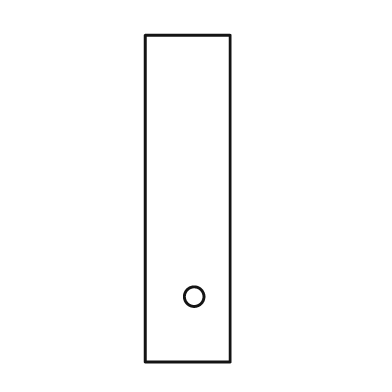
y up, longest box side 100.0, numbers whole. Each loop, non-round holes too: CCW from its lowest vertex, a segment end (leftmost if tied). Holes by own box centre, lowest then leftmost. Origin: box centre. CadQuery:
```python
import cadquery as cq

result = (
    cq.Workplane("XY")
    .moveTo(-13.0, -50.0)
    .lineTo(13.0, -50.0)
    .lineTo(13.0, 50.0)
    .lineTo(-13.0, 50.0)
    .close()
    .moveTo(2.0, -30.0)
    .circle(3.0)
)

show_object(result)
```